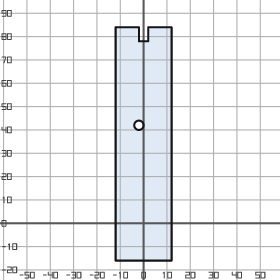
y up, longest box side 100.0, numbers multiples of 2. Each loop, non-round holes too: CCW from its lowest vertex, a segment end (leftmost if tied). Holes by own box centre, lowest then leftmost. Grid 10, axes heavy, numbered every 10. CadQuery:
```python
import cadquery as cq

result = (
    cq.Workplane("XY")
    .moveTo(-12.0, -16.0)
    .lineTo(12.0, -16.0)
    .lineTo(12.0, 84.0)
    .lineTo(2.0, 84.0)
    .lineTo(2.0, 78.0)
    .lineTo(-2.0, 78.0)
    .lineTo(-2.0, 84.0)
    .lineTo(-12.0, 84.0)
    .close()
    .moveTo(-2.0, 42.0)
    .circle(2.0)
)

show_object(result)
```